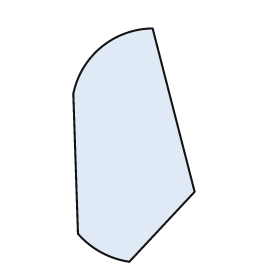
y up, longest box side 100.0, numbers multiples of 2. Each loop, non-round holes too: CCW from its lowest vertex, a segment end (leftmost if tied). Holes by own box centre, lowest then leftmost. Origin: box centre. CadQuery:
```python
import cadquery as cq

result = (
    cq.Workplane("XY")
    .moveTo(-2.0, -50.0)
    .lineTo(26.0, -20.0)
    .lineTo(8.0, 50.0)
    .threePointArc((-14.0, 42.0), (-26.0, 22.0))
    .lineTo(-24.0, -38.0)
    .threePointArc((-14.0, -46.0), (-2.0, -50.0))
    .close()
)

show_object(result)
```